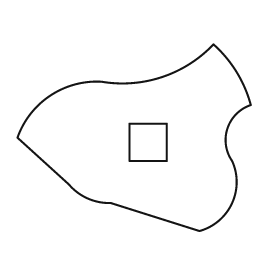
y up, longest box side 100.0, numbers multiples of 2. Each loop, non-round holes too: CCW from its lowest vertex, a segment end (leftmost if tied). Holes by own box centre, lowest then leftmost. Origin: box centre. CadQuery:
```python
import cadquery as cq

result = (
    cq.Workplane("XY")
    .moveTo(28.0, -40.0)
    .threePointArc((42.0, -28.0), (42.0, -10.0))
    .threePointArc((40.0, 4.0), (50.0, 14.0))
    .threePointArc((44.0, 28.0), (34.0, 40.0))
    .threePointArc((12.0, 26.0), (-14.0, 24.0))
    .threePointArc((-36.0, 18.0), (-50.0, 0.0))
    .lineTo(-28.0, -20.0)
    .threePointArc((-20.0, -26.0), (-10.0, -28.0))
    .close()
    .moveTo(-2.0, -10.0)
    .lineTo(14.0, -10.0)
    .lineTo(14.0, 6.0)
    .lineTo(-2.0, 6.0)
    .close()
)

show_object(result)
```